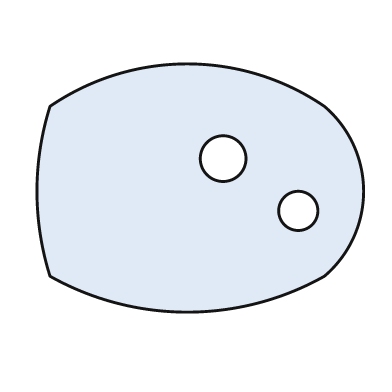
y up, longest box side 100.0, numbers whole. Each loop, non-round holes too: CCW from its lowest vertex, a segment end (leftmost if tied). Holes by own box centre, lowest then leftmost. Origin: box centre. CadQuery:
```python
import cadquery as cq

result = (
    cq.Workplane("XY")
    .moveTo(-46.0, -27.0)
    .threePointArc((-4.0, -38.0), (38.0, -27.0))
    .threePointArc((50.0, -1.0), (38.0, 25.0))
    .threePointArc((-4.0, 38.0), (-46.0, 25.0))
    .threePointArc((-50.0, -1.0), (-46.0, -27.0))
    .close()
    .moveTo(30.0, -7.0)
    .circle(6.0)
    .moveTo(7.0, 9.0)
    .circle(7.0)
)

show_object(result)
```